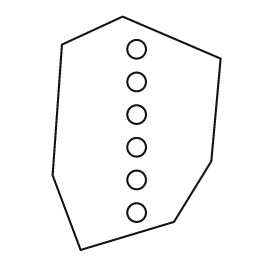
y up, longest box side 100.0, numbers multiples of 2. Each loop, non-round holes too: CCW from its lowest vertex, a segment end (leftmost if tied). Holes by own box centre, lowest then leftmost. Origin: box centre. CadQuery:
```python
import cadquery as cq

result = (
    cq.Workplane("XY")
    .moveTo(-24.0, -50.0)
    .lineTo(16.0, -38.0)
    .lineTo(32.0, -12.0)
    .lineTo(36.0, 32.0)
    .lineTo(-6.0, 50.0)
    .lineTo(-32.0, 38.0)
    .lineTo(-36.0, -18.0)
    .close()
    .moveTo(0.0, -34.0)
    .circle(4.0)
    .moveTo(0.0, -20.0)
    .circle(4.0)
    .moveTo(0.0, -6.0)
    .circle(4.0)
    .moveTo(0.0, 8.0)
    .circle(4.0)
    .moveTo(0.0, 22.0)
    .circle(4.0)
    .moveTo(0.0, 36.0)
    .circle(4.0)
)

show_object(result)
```